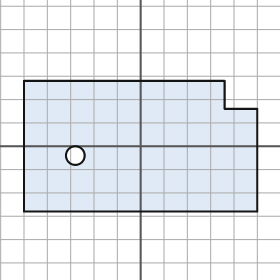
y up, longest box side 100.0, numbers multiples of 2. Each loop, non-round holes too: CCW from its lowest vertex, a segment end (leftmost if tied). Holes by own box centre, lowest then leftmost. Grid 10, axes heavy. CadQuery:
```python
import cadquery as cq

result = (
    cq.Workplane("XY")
    .moveTo(-50.0, -28.0)
    .lineTo(50.0, -28.0)
    .lineTo(50.0, 16.0)
    .lineTo(36.0, 16.0)
    .lineTo(36.0, 28.0)
    .lineTo(-50.0, 28.0)
    .close()
    .moveTo(-28.0, -4.0)
    .circle(4.0)
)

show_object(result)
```